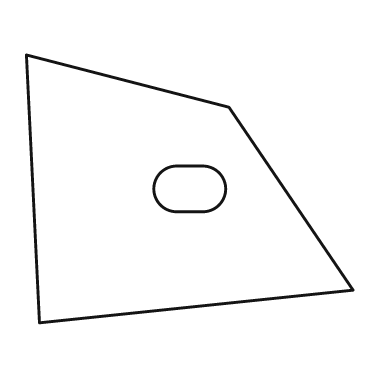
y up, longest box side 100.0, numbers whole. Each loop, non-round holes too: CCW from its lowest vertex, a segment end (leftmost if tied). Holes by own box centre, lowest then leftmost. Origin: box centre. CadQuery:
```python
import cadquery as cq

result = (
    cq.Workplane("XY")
    .moveTo(-46.0, -41.0)
    .lineTo(50.0, -31.0)
    .lineTo(12.0, 25.0)
    .lineTo(-50.0, 41.0)
    .close()
    .moveTo(-4.0, -7.0)
    .lineTo(4.0, -7.0)
    .threePointArc((11.0, 0.0), (4.0, 7.0))
    .lineTo(-4.0, 7.0)
    .threePointArc((-11.0, 0.0), (-4.0, -7.0))
    .close()
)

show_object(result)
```